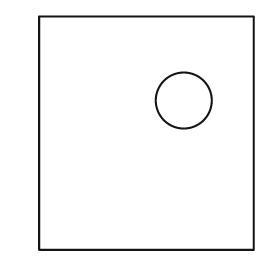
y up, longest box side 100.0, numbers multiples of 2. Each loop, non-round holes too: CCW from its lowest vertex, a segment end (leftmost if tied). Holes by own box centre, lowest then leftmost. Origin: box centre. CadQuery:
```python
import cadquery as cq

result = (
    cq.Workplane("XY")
    .moveTo(-46.0, -50.0)
    .lineTo(46.0, -50.0)
    .lineTo(46.0, 50.0)
    .lineTo(-46.0, 50.0)
    .close()
    .moveTo(16.0, 14.0)
    .circle(12.0)
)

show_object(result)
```